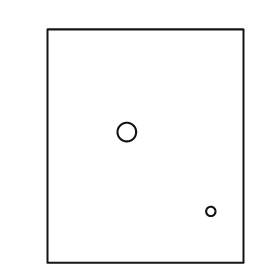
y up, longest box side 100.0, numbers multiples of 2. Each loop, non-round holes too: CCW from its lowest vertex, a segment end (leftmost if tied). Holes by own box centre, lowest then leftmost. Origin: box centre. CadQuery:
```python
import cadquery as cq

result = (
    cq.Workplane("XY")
    .moveTo(-42.0, -50.0)
    .lineTo(42.0, -50.0)
    .lineTo(42.0, 50.0)
    .lineTo(-42.0, 50.0)
    .close()
    .moveTo(28.0, -28.0)
    .circle(2.0)
    .moveTo(-8.0, 6.0)
    .circle(4.0)
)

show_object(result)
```